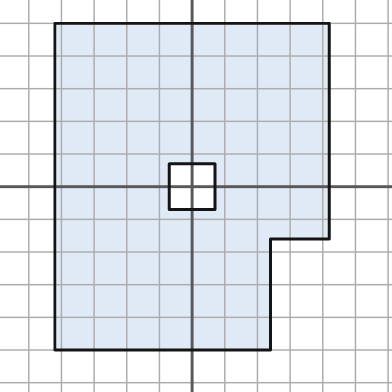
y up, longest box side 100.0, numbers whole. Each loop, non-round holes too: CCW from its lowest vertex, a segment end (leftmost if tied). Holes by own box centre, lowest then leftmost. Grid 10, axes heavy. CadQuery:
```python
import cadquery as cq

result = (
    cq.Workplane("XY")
    .moveTo(-42.0, -50.0)
    .lineTo(24.0, -50.0)
    .lineTo(24.0, -16.0)
    .lineTo(42.0, -16.0)
    .lineTo(42.0, 50.0)
    .lineTo(-42.0, 50.0)
    .close()
    .moveTo(-7.0, -7.0)
    .lineTo(7.0, -7.0)
    .lineTo(7.0, 7.0)
    .lineTo(-7.0, 7.0)
    .close()
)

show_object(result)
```